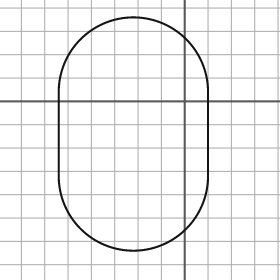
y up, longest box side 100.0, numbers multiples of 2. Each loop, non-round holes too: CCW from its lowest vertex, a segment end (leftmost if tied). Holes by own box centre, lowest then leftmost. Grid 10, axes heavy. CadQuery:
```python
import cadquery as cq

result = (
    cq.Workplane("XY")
    .moveTo(-54.0, -32.0)
    .threePointArc((-22.0, -64.0), (10.0, -32.0))
    .lineTo(10.0, 4.0)
    .threePointArc((-22.0, 36.0), (-54.0, 4.0))
    .close()
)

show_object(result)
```